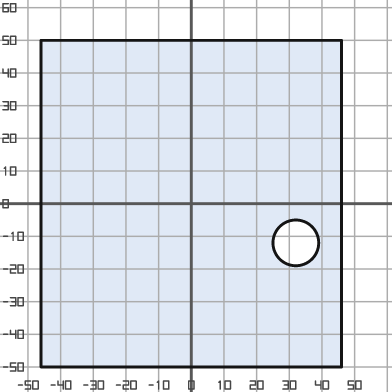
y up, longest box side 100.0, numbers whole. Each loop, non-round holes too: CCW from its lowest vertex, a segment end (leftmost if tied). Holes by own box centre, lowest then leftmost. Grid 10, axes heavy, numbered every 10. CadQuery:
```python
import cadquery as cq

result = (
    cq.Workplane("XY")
    .moveTo(-46.0, -50.0)
    .lineTo(46.0, -50.0)
    .lineTo(46.0, 50.0)
    .lineTo(-46.0, 50.0)
    .close()
    .moveTo(32.0, -12.0)
    .circle(7.0)
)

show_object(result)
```